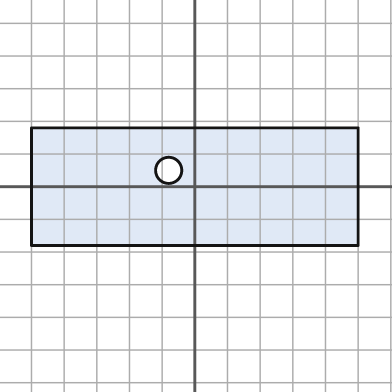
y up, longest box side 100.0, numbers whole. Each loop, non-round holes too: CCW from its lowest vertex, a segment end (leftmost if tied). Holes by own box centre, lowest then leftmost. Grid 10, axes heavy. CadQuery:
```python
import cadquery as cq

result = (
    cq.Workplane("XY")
    .moveTo(-50.0, -18.0)
    .lineTo(50.0, -18.0)
    .lineTo(50.0, 18.0)
    .lineTo(-50.0, 18.0)
    .close()
    .moveTo(-8.0, 5.0)
    .circle(4.0)
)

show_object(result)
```